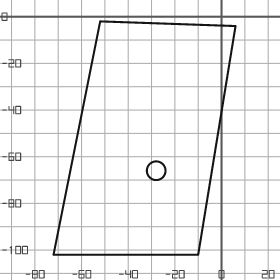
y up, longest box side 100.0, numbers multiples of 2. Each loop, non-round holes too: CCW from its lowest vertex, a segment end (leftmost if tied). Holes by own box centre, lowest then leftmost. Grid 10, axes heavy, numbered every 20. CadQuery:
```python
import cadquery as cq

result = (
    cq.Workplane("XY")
    .moveTo(-72.0, -102.0)
    .lineTo(-10.0, -102.0)
    .lineTo(6.0, -4.0)
    .lineTo(-52.0, -2.0)
    .close()
    .moveTo(-28.0, -66.0)
    .circle(4.0)
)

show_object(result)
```